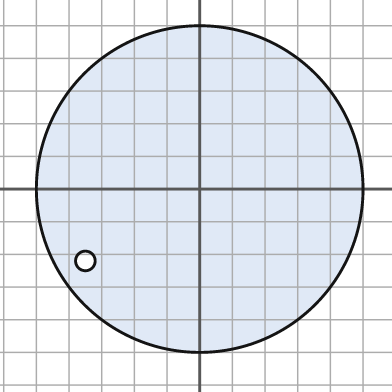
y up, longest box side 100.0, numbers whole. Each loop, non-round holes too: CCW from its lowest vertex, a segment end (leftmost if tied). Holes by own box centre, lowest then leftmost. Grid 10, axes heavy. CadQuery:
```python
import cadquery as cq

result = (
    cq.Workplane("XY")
    .moveTo(0.0, 0.0)
    .circle(50.0)
    .moveTo(-35.0, -22.0)
    .circle(3.0)
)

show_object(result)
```